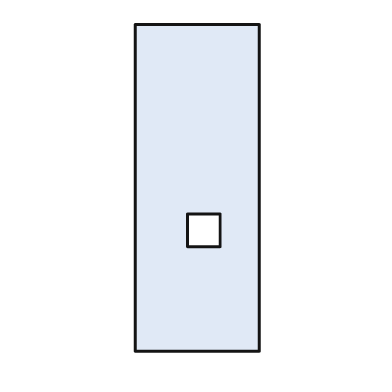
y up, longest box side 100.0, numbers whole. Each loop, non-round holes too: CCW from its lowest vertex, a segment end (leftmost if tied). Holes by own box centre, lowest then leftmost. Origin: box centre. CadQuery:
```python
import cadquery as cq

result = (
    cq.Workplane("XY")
    .moveTo(-19.0, -50.0)
    .lineTo(19.0, -50.0)
    .lineTo(19.0, 50.0)
    .lineTo(-19.0, 50.0)
    .close()
    .moveTo(-3.0, -18.0)
    .lineTo(7.0, -18.0)
    .lineTo(7.0, -8.0)
    .lineTo(-3.0, -8.0)
    .close()
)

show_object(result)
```